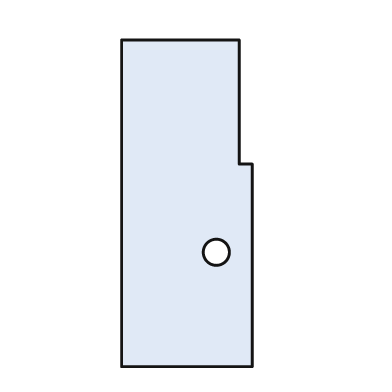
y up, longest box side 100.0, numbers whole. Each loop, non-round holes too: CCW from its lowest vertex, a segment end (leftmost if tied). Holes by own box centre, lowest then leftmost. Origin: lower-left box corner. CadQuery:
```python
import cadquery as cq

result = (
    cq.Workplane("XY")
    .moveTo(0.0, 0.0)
    .lineTo(40.0, 0.0)
    .lineTo(40.0, 62.0)
    .lineTo(36.0, 62.0)
    .lineTo(36.0, 100.0)
    .lineTo(0.0, 100.0)
    .close()
    .moveTo(29.0, 35.0)
    .circle(4.0)
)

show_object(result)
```